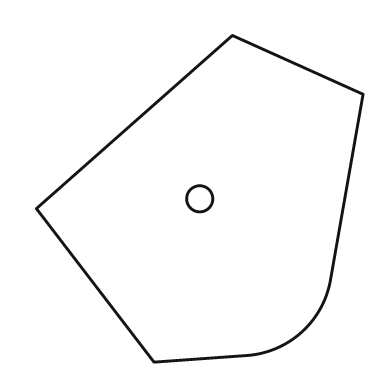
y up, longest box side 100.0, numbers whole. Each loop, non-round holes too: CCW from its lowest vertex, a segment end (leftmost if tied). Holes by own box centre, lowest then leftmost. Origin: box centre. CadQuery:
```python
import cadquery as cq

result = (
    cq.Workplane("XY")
    .moveTo(-14.0, -50.0)
    .lineTo(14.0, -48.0)
    .threePointArc((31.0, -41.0), (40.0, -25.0))
    .lineTo(50.0, 32.0)
    .lineTo(10.0, 50.0)
    .lineTo(-50.0, -3.0)
    .close()
    .moveTo(0.0, 0.0)
    .circle(4.0)
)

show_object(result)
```